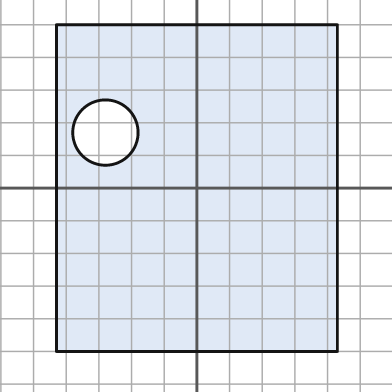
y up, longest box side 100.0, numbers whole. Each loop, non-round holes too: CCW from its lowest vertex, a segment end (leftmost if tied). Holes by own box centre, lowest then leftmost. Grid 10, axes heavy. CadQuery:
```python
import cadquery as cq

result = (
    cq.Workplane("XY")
    .moveTo(-43.0, -50.0)
    .lineTo(43.0, -50.0)
    .lineTo(43.0, 50.0)
    .lineTo(-43.0, 50.0)
    .close()
    .moveTo(-28.0, 17.0)
    .circle(10.0)
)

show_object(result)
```